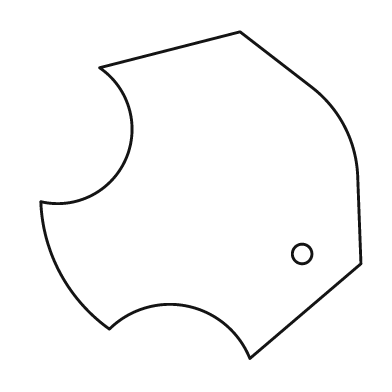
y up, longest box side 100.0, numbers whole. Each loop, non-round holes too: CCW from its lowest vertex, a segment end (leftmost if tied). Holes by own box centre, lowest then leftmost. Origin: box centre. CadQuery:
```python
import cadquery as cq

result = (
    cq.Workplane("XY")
    .moveTo(15.0, -50.0)
    .lineTo(49.0, -21.0)
    .lineTo(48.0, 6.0)
    .threePointArc((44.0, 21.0), (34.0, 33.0))
    .lineTo(12.0, 50.0)
    .lineTo(-31.0, 39.0)
    .threePointArc((-23.0, 11.0), (-49.0, -2.0))
    .threePointArc((-43.0, -24.0), (-28.0, -41.0))
    .threePointArc((-4.0, -34.0), (15.0, -50.0))
    .close()
    .moveTo(31.0, -18.0)
    .circle(3.0)
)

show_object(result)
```